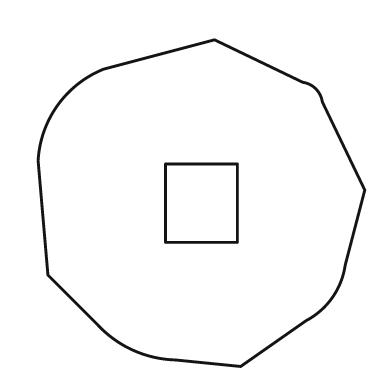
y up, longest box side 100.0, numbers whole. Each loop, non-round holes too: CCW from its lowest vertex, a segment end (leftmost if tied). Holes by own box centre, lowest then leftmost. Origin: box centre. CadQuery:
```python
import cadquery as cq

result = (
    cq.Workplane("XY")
    .moveTo(12.0, -50.0)
    .lineTo(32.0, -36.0)
    .threePointArc((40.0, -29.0), (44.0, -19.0))
    .lineTo(50.0, 4.0)
    .lineTo(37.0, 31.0)
    .threePointArc((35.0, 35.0), (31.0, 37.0))
    .lineTo(4.0, 50.0)
    .lineTo(-30.0, 41.0)
    .threePointArc((-44.0, 30.0), (-50.0, 13.0))
    .lineTo(-47.0, -22.0)
    .lineTo(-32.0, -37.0)
    .threePointArc((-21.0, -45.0), (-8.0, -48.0))
    .close()
    .moveTo(-11.0, -12.0)
    .lineTo(11.0, -12.0)
    .lineTo(11.0, 12.0)
    .lineTo(-11.0, 12.0)
    .close()
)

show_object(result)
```